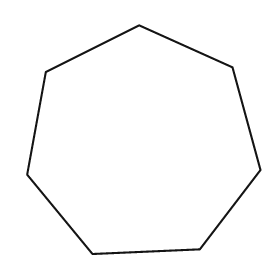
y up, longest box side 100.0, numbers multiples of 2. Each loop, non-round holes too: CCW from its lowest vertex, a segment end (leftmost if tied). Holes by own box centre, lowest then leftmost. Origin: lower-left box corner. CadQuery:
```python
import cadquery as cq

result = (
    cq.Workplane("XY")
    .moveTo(28.0, 0.0)
    .lineTo(74.0, 2.0)
    .lineTo(100.0, 36.0)
    .lineTo(88.0, 80.0)
    .lineTo(48.0, 98.0)
    .lineTo(8.0, 78.0)
    .lineTo(0.0, 34.0)
    .close()
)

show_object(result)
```